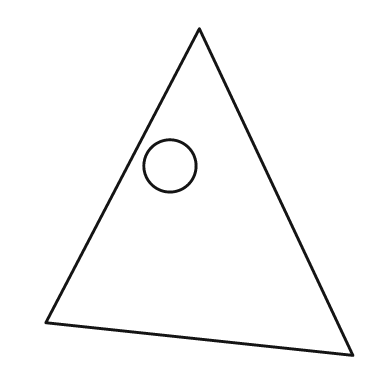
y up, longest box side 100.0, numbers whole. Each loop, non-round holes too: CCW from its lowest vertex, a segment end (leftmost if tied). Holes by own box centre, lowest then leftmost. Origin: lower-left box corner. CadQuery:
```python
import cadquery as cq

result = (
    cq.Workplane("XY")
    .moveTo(94.0, 0.0)
    .lineTo(47.0, 100.0)
    .lineTo(0.0, 10.0)
    .close()
    .moveTo(38.0, 58.0)
    .circle(8.0)
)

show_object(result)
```